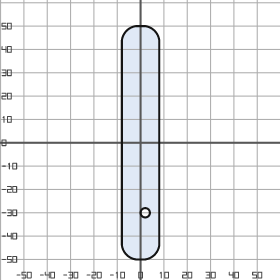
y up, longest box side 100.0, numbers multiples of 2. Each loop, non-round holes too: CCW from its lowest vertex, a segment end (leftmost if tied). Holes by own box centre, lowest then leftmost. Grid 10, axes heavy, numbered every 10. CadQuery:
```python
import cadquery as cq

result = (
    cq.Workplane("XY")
    .moveTo(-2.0, -50.0)
    .lineTo(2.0, -50.0)
    .threePointArc((6.0, -48.0), (8.0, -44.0))
    .lineTo(8.0, 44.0)
    .threePointArc((6.0, 48.0), (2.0, 50.0))
    .lineTo(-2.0, 50.0)
    .threePointArc((-6.0, 48.0), (-8.0, 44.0))
    .lineTo(-8.0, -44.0)
    .threePointArc((-6.0, -48.0), (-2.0, -50.0))
    .close()
    .moveTo(2.0, -30.0)
    .circle(2.0)
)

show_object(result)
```